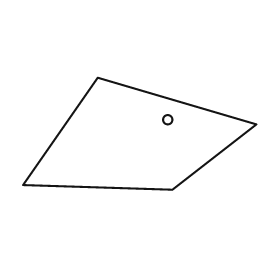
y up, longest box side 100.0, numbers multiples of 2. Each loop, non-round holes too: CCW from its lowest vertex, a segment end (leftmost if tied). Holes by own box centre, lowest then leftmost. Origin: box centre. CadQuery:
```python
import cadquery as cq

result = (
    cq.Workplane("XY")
    .moveTo(14.0, -24.0)
    .lineTo(50.0, 4.0)
    .lineTo(-18.0, 24.0)
    .lineTo(-50.0, -22.0)
    .close()
    .moveTo(12.0, 6.0)
    .circle(2.0)
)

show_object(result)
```